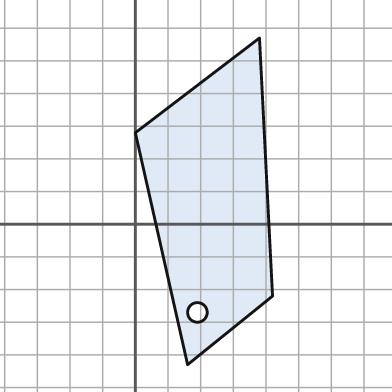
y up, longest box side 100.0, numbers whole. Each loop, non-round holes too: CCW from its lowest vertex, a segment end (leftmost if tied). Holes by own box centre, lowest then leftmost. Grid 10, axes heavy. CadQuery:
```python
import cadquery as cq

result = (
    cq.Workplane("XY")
    .moveTo(16.0, -43.0)
    .lineTo(42.0, -22.0)
    .lineTo(38.0, 57.0)
    .lineTo(0.0, 28.0)
    .close()
    .moveTo(19.0, -27.0)
    .circle(3.0)
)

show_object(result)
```